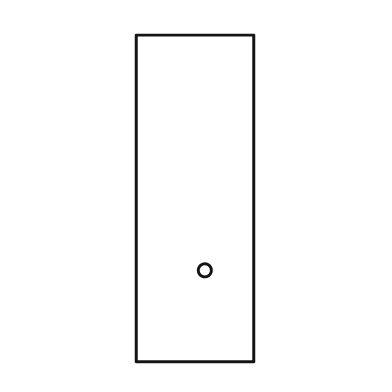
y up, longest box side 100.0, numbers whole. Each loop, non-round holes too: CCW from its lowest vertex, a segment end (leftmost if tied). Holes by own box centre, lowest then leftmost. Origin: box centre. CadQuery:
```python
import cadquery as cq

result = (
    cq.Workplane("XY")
    .moveTo(-18.0, -50.0)
    .lineTo(18.0, -50.0)
    .lineTo(18.0, 50.0)
    .lineTo(-18.0, 50.0)
    .close()
    .moveTo(3.0, -22.0)
    .circle(2.0)
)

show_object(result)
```